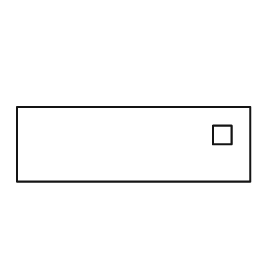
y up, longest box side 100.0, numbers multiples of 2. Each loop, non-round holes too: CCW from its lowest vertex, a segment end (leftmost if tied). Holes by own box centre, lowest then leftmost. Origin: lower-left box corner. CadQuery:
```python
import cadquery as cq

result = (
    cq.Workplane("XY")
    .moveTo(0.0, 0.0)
    .lineTo(100.0, 0.0)
    .lineTo(100.0, 32.0)
    .lineTo(0.0, 32.0)
    .close()
    .moveTo(84.0, 16.0)
    .lineTo(92.0, 16.0)
    .lineTo(92.0, 24.0)
    .lineTo(84.0, 24.0)
    .close()
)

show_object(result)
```